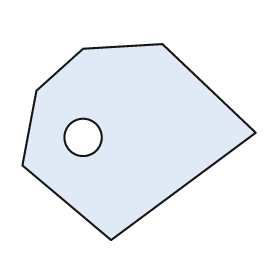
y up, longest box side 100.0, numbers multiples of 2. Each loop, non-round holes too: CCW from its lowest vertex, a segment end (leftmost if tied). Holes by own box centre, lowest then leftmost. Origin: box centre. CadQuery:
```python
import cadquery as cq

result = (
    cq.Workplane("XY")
    .moveTo(-12.0, -42.0)
    .lineTo(50.0, 4.0)
    .lineTo(10.0, 42.0)
    .lineTo(-24.0, 40.0)
    .lineTo(-44.0, 22.0)
    .lineTo(-50.0, -10.0)
    .close()
    .moveTo(-24.0, 2.0)
    .circle(8.0)
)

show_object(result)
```